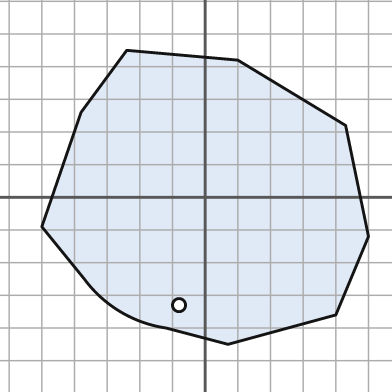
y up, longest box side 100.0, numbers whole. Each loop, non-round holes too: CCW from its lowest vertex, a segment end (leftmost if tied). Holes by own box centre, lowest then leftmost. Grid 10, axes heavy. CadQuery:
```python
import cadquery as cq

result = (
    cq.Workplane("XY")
    .moveTo(7.0, -45.0)
    .lineTo(40.0, -36.0)
    .lineTo(50.0, -12.0)
    .lineTo(43.0, 22.0)
    .lineTo(10.0, 42.0)
    .lineTo(-24.0, 45.0)
    .lineTo(-38.0, 26.0)
    .lineTo(-50.0, -9.0)
    .lineTo(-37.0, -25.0)
    .threePointArc((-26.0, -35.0), (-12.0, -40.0))
    .close()
    .moveTo(-8.0, -33.0)
    .circle(2.0)
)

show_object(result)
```